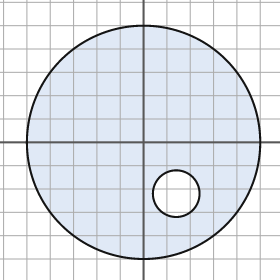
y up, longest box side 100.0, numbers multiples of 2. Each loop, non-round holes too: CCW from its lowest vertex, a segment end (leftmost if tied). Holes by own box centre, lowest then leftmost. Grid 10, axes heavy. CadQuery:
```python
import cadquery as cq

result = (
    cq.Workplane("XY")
    .moveTo(0.0, 0.0)
    .circle(50.0)
    .moveTo(14.0, -22.0)
    .circle(10.0)
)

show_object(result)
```